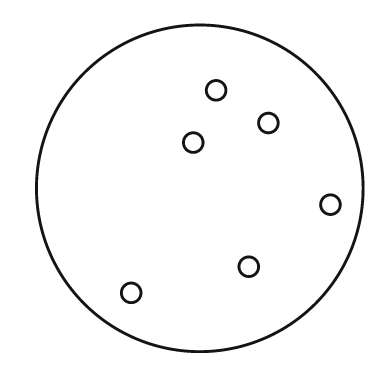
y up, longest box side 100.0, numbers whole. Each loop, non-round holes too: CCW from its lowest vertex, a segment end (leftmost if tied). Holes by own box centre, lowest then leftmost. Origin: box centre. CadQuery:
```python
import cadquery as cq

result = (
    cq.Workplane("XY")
    .moveTo(0.0, 0.0)
    .circle(50.0)
    .moveTo(-21.0, -32.0)
    .circle(3.0)
    .moveTo(15.0, -24.0)
    .circle(3.0)
    .moveTo(40.0, -5.0)
    .circle(3.0)
    .moveTo(-2.0, 14.0)
    .circle(3.0)
    .moveTo(21.0, 20.0)
    .circle(3.0)
    .moveTo(5.0, 30.0)
    .circle(3.0)
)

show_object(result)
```